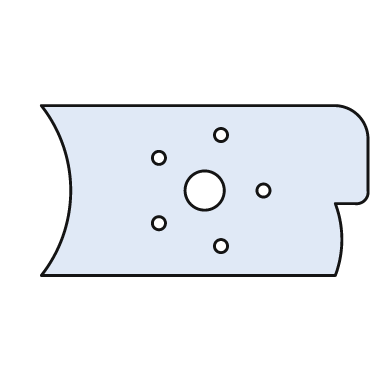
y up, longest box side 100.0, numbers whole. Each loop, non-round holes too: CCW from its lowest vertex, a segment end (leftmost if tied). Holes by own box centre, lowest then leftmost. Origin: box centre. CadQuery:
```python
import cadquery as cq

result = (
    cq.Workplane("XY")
    .moveTo(-50.0, -26.0)
    .lineTo(40.0, -26.0)
    .threePointArc((42.0, -15.0), (40.0, -4.0))
    .lineTo(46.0, -4.0)
    .threePointArc((49.0, -3.0), (50.0, 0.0))
    .lineTo(50.0, 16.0)
    .threePointArc((47.0, 23.0), (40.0, 26.0))
    .lineTo(-50.0, 26.0)
    .threePointArc((-41.0, 0.0), (-50.0, -26.0))
    .close()
    .moveTo(5.0, -17.0)
    .circle(2.0)
    .moveTo(-14.0, -10.0)
    .circle(2.0)
    .moveTo(0.0, 0.0)
    .circle(6.0)
    .moveTo(18.0, 0.0)
    .circle(2.0)
    .moveTo(-14.0, 10.0)
    .circle(2.0)
    .moveTo(5.0, 17.0)
    .circle(2.0)
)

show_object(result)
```